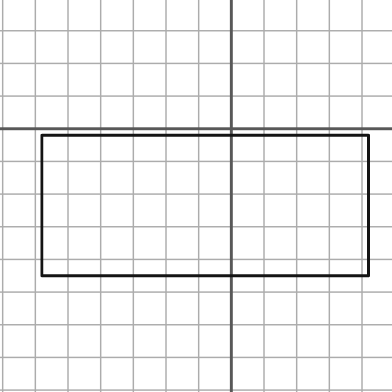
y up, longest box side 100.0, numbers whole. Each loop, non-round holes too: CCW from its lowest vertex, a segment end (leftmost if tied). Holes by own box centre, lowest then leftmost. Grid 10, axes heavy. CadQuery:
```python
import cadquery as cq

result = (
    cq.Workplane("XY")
    .moveTo(-58.0, -45.0)
    .lineTo(42.0, -45.0)
    .lineTo(42.0, -2.0)
    .lineTo(-58.0, -2.0)
    .close()
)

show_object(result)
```